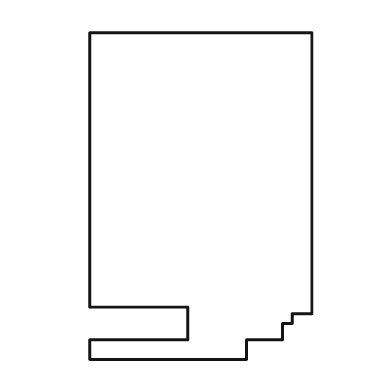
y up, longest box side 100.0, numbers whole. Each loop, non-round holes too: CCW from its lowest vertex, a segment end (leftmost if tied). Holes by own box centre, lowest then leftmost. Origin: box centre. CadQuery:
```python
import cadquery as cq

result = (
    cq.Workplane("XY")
    .moveTo(-34.0, -50.0)
    .lineTo(14.0, -50.0)
    .lineTo(14.0, -44.0)
    .lineTo(25.0, -44.0)
    .lineTo(25.0, -39.0)
    .lineTo(28.0, -39.0)
    .lineTo(28.0, -36.0)
    .lineTo(34.0, -36.0)
    .lineTo(34.0, 50.0)
    .lineTo(-34.0, 50.0)
    .lineTo(-34.0, -34.0)
    .lineTo(-4.0, -34.0)
    .lineTo(-4.0, -44.0)
    .lineTo(-34.0, -44.0)
    .close()
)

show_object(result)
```